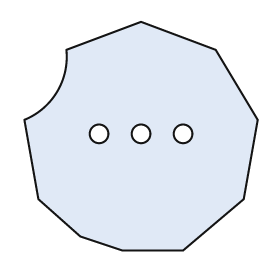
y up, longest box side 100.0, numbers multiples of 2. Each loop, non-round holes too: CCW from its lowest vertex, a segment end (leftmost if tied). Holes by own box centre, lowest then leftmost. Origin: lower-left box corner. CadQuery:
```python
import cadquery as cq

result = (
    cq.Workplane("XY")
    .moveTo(42.0, 0.0)
    .lineTo(68.0, 0.0)
    .lineTo(94.0, 22.0)
    .lineTo(100.0, 56.0)
    .lineTo(82.0, 86.0)
    .lineTo(50.0, 98.0)
    .lineTo(18.0, 86.0)
    .threePointArc((14.0, 68.0), (0.0, 56.0))
    .lineTo(6.0, 22.0)
    .lineTo(24.0, 6.0)
    .close()
    .moveTo(32.0, 50.0)
    .circle(4.0)
    .moveTo(50.0, 50.0)
    .circle(4.0)
    .moveTo(68.0, 50.0)
    .circle(4.0)
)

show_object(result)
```